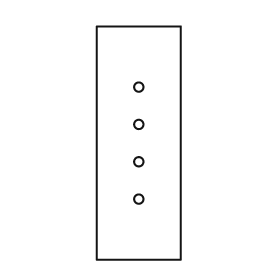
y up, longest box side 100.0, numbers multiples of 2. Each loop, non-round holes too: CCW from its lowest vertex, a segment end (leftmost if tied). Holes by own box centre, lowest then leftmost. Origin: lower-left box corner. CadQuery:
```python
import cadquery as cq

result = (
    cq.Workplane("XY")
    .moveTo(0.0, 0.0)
    .lineTo(36.0, 0.0)
    .lineTo(36.0, 100.0)
    .lineTo(0.0, 100.0)
    .close()
    .moveTo(18.0, 26.0)
    .circle(2.0)
    .moveTo(18.0, 42.0)
    .circle(2.0)
    .moveTo(18.0, 58.0)
    .circle(2.0)
    .moveTo(18.0, 74.0)
    .circle(2.0)
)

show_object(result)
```